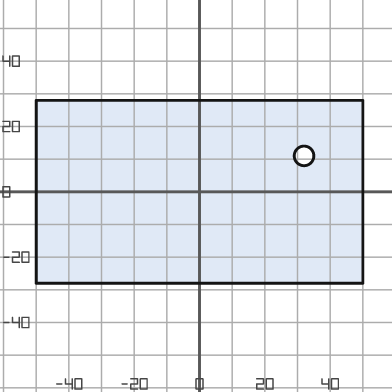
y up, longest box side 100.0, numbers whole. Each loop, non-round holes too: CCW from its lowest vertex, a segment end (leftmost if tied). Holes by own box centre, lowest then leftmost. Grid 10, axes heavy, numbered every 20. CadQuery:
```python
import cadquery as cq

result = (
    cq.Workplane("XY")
    .moveTo(-50.0, -28.0)
    .lineTo(50.0, -28.0)
    .lineTo(50.0, 28.0)
    .lineTo(-50.0, 28.0)
    .close()
    .moveTo(32.0, 11.0)
    .circle(3.0)
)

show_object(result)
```